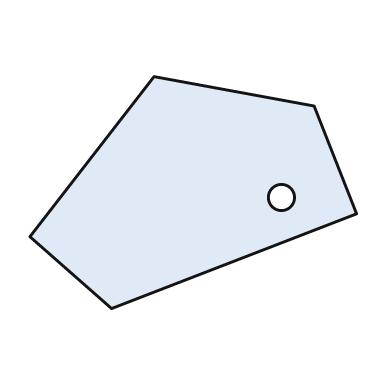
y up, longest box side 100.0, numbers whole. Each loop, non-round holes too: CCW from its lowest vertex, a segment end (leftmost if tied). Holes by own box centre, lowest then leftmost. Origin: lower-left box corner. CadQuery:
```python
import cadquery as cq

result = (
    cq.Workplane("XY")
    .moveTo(25.0, 0.0)
    .lineTo(100.0, 29.0)
    .lineTo(87.0, 62.0)
    .lineTo(38.0, 71.0)
    .lineTo(0.0, 22.0)
    .close()
    .moveTo(77.0, 34.0)
    .circle(4.0)
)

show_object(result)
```